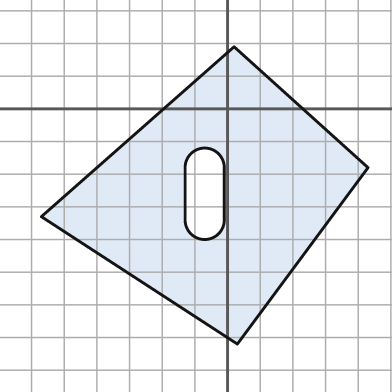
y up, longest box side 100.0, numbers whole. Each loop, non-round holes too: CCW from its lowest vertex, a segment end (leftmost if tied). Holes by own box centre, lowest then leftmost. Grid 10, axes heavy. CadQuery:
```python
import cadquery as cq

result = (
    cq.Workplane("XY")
    .moveTo(3.0, -72.0)
    .lineTo(43.0, -18.0)
    .lineTo(2.0, 19.0)
    .lineTo(-57.0, -33.0)
    .close()
    .moveTo(-13.0, -34.0)
    .threePointArc((-7.0, -40.0), (-1.0, -34.0))
    .lineTo(-1.0, -18.0)
    .threePointArc((-7.0, -12.0), (-13.0, -18.0))
    .close()
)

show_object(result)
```